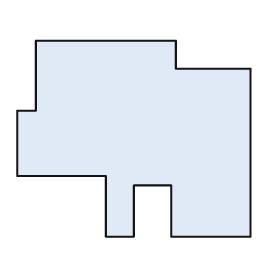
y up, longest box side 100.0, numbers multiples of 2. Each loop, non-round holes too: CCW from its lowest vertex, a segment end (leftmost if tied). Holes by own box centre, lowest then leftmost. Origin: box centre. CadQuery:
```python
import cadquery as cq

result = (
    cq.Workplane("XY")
    .moveTo(-12.0, -42.0)
    .lineTo(0.0, -42.0)
    .lineTo(0.0, -20.0)
    .lineTo(16.0, -20.0)
    .lineTo(16.0, -42.0)
    .lineTo(50.0, -42.0)
    .lineTo(50.0, 30.0)
    .lineTo(18.0, 30.0)
    .lineTo(18.0, 42.0)
    .lineTo(-42.0, 42.0)
    .lineTo(-42.0, 12.0)
    .lineTo(-50.0, 12.0)
    .lineTo(-50.0, -16.0)
    .lineTo(-12.0, -16.0)
    .close()
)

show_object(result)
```